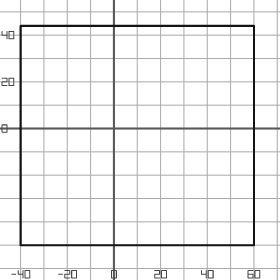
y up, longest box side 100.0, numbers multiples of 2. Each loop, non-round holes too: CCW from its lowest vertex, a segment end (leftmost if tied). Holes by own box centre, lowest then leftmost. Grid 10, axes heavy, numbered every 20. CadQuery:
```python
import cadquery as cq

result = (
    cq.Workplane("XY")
    .moveTo(-40.0, -50.0)
    .lineTo(60.0, -50.0)
    .lineTo(60.0, 44.0)
    .lineTo(-40.0, 44.0)
    .close()
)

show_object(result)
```